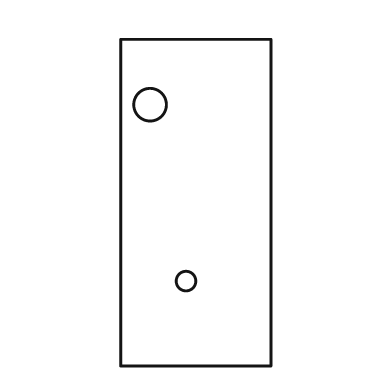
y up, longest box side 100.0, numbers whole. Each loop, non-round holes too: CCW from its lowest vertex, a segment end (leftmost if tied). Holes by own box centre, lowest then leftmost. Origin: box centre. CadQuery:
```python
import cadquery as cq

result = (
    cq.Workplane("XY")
    .moveTo(-23.0, -50.0)
    .lineTo(23.0, -50.0)
    .lineTo(23.0, 50.0)
    .lineTo(-23.0, 50.0)
    .close()
    .moveTo(-3.0, -24.0)
    .circle(3.0)
    .moveTo(-14.0, 30.0)
    .circle(5.0)
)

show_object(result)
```